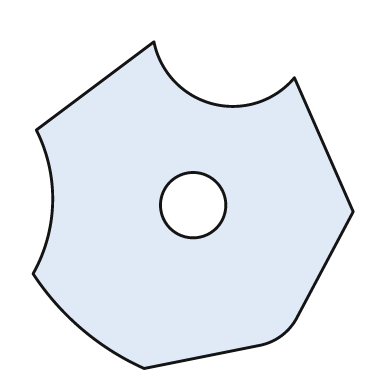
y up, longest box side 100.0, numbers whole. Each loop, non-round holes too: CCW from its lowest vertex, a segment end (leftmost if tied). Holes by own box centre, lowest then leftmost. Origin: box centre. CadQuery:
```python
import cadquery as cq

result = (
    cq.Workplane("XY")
    .moveTo(-15.0, -50.0)
    .lineTo(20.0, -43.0)
    .threePointArc((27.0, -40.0), (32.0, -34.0))
    .lineTo(49.0, -2.0)
    .lineTo(31.0, 39.0)
    .threePointArc((6.0, 31.0), (-12.0, 50.0))
    .lineTo(-48.0, 23.0)
    .threePointArc((-43.0, 1.0), (-49.0, -21.0))
    .threePointArc((-34.0, -38.0), (-15.0, -50.0))
    .close()
    .moveTo(0.0, 0.0)
    .circle(10.0)
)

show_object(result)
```